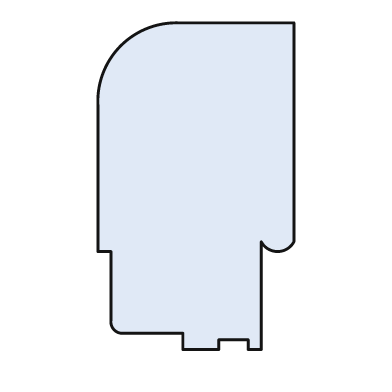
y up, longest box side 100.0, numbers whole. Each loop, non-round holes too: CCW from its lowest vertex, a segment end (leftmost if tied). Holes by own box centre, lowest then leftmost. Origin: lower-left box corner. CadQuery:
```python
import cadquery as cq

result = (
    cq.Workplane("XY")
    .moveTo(26.0, 0.0)
    .lineTo(37.0, 0.0)
    .lineTo(37.0, 3.0)
    .lineTo(46.0, 3.0)
    .lineTo(46.0, 0.0)
    .lineTo(50.0, 0.0)
    .lineTo(50.0, 33.0)
    .threePointArc((55.0, 30.0), (60.0, 33.0))
    .lineTo(60.0, 100.0)
    .lineTo(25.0, 100.0)
    .threePointArc((7.0, 93.0), (0.0, 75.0))
    .lineTo(0.0, 30.0)
    .lineTo(4.0, 30.0)
    .lineTo(4.0, 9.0)
    .threePointArc((5.0, 6.0), (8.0, 5.0))
    .lineTo(26.0, 5.0)
    .close()
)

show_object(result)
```